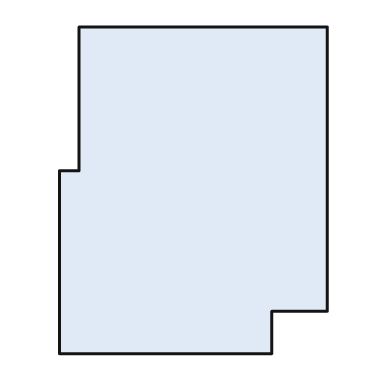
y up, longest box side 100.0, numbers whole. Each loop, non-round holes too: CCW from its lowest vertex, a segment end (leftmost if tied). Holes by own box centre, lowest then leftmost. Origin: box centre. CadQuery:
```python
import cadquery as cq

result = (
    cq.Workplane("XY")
    .moveTo(-41.0, -50.0)
    .lineTo(24.0, -50.0)
    .lineTo(24.0, -37.0)
    .lineTo(41.0, -37.0)
    .lineTo(41.0, 50.0)
    .lineTo(-35.0, 50.0)
    .lineTo(-35.0, 6.0)
    .lineTo(-41.0, 6.0)
    .close()
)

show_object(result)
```